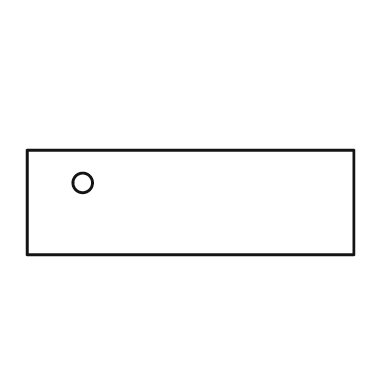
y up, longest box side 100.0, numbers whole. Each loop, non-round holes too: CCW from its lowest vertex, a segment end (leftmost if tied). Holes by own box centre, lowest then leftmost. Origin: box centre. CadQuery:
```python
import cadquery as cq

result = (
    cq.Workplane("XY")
    .moveTo(-50.0, -16.0)
    .lineTo(50.0, -16.0)
    .lineTo(50.0, 16.0)
    .lineTo(-50.0, 16.0)
    .close()
    .moveTo(-33.0, 6.0)
    .circle(3.0)
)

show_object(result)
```